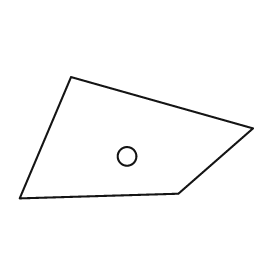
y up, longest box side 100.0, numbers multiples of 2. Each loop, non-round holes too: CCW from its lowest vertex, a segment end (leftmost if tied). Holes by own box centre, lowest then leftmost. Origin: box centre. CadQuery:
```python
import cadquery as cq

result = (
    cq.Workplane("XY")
    .moveTo(-50.0, -26.0)
    .lineTo(18.0, -24.0)
    .lineTo(50.0, 4.0)
    .lineTo(-28.0, 26.0)
    .close()
    .moveTo(-4.0, -8.0)
    .circle(4.0)
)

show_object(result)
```